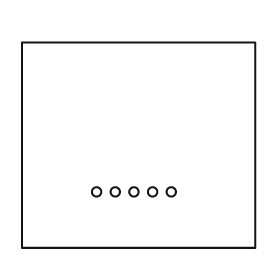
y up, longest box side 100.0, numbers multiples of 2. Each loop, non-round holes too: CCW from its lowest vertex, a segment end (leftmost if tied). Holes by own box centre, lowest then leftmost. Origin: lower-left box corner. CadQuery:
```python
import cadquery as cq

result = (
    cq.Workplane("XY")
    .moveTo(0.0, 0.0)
    .lineTo(100.0, 0.0)
    .lineTo(100.0, 88.0)
    .lineTo(0.0, 88.0)
    .close()
    .moveTo(32.0, 24.0)
    .circle(2.0)
    .moveTo(40.0, 24.0)
    .circle(2.0)
    .moveTo(48.0, 24.0)
    .circle(2.0)
    .moveTo(56.0, 24.0)
    .circle(2.0)
    .moveTo(64.0, 24.0)
    .circle(2.0)
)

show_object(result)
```